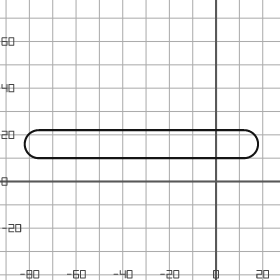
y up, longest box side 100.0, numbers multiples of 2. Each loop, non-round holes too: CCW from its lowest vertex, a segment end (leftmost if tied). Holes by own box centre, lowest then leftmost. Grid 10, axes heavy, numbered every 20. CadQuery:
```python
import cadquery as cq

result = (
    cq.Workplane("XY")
    .moveTo(-76.0, 10.0)
    .lineTo(12.0, 10.0)
    .threePointArc((18.0, 16.0), (12.0, 22.0))
    .lineTo(-76.0, 22.0)
    .threePointArc((-82.0, 16.0), (-76.0, 10.0))
    .close()
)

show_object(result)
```